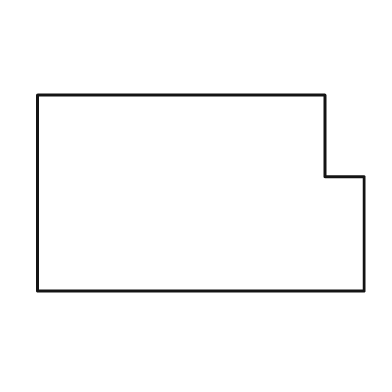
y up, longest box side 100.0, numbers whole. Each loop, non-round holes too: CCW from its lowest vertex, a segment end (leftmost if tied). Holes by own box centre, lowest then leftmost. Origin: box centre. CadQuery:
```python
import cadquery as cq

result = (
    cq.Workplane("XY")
    .moveTo(-50.0, -30.0)
    .lineTo(50.0, -30.0)
    .lineTo(50.0, 5.0)
    .lineTo(38.0, 5.0)
    .lineTo(38.0, 30.0)
    .lineTo(-50.0, 30.0)
    .close()
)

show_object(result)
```